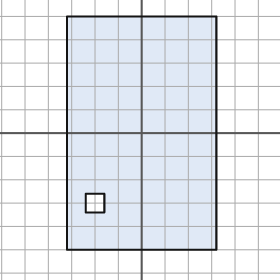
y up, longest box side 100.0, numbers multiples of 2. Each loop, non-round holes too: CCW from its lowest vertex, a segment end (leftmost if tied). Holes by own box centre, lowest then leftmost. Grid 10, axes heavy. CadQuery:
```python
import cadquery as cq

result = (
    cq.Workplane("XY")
    .moveTo(-32.0, -50.0)
    .lineTo(32.0, -50.0)
    .lineTo(32.0, 50.0)
    .lineTo(-32.0, 50.0)
    .close()
    .moveTo(-24.0, -34.0)
    .lineTo(-16.0, -34.0)
    .lineTo(-16.0, -26.0)
    .lineTo(-24.0, -26.0)
    .close()
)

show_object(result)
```